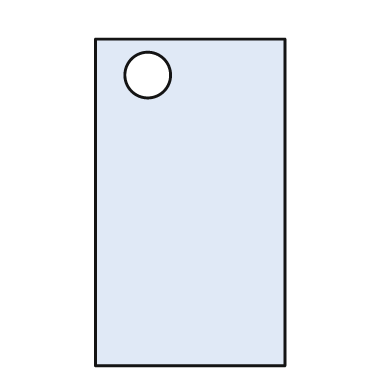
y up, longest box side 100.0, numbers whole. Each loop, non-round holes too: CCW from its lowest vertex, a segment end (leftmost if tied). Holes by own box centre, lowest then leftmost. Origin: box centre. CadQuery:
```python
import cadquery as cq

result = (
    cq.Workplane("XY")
    .moveTo(-29.0, -50.0)
    .lineTo(29.0, -50.0)
    .lineTo(29.0, 50.0)
    .lineTo(-29.0, 50.0)
    .close()
    .moveTo(-13.0, 39.0)
    .circle(7.0)
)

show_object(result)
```